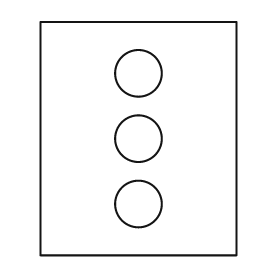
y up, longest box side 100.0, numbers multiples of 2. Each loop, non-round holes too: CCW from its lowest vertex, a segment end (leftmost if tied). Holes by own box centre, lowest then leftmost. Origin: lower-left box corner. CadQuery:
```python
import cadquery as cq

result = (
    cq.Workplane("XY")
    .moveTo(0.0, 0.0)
    .lineTo(84.0, 0.0)
    .lineTo(84.0, 100.0)
    .lineTo(0.0, 100.0)
    .close()
    .moveTo(42.0, 22.0)
    .circle(10.0)
    .moveTo(42.0, 50.0)
    .circle(10.0)
    .moveTo(42.0, 78.0)
    .circle(10.0)
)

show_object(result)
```